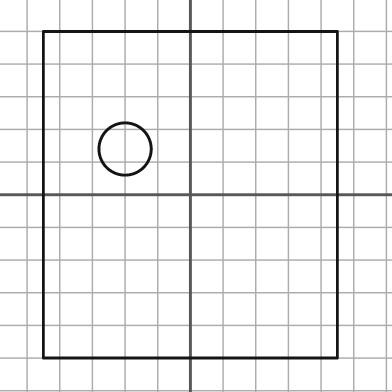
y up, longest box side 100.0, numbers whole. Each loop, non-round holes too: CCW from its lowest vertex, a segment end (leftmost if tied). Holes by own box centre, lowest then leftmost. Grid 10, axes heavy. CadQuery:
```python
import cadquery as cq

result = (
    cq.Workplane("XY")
    .moveTo(-45.0, -50.0)
    .lineTo(45.0, -50.0)
    .lineTo(45.0, 50.0)
    .lineTo(-45.0, 50.0)
    .close()
    .moveTo(-20.0, 14.0)
    .circle(8.0)
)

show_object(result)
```